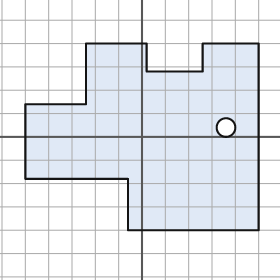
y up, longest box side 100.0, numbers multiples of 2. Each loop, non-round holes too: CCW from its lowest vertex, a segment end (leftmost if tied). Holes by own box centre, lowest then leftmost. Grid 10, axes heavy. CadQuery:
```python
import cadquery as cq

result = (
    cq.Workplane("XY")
    .moveTo(-6.0, -40.0)
    .lineTo(50.0, -40.0)
    .lineTo(50.0, 40.0)
    .lineTo(26.0, 40.0)
    .lineTo(26.0, 28.0)
    .lineTo(2.0, 28.0)
    .lineTo(2.0, 40.0)
    .lineTo(-24.0, 40.0)
    .lineTo(-24.0, 14.0)
    .lineTo(-50.0, 14.0)
    .lineTo(-50.0, -18.0)
    .lineTo(-6.0, -18.0)
    .close()
    .moveTo(36.0, 4.0)
    .circle(4.0)
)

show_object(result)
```